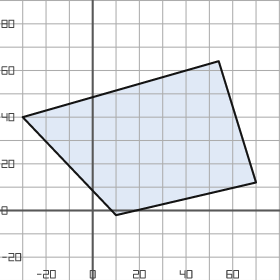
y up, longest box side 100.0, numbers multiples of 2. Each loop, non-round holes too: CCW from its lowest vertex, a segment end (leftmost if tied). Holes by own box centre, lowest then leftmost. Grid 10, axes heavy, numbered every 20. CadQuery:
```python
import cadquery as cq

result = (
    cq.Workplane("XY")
    .moveTo(10.0, -2.0)
    .lineTo(70.0, 12.0)
    .lineTo(54.0, 64.0)
    .lineTo(-30.0, 40.0)
    .close()
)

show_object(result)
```